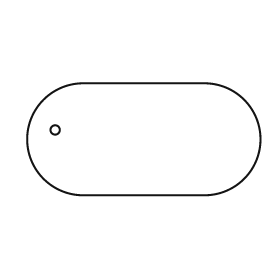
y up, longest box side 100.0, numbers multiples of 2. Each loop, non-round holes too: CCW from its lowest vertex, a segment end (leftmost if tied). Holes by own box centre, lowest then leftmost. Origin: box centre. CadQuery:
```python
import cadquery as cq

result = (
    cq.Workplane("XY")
    .moveTo(-26.0, -24.0)
    .lineTo(26.0, -24.0)
    .threePointArc((50.0, 0.0), (26.0, 24.0))
    .lineTo(-26.0, 24.0)
    .threePointArc((-50.0, 0.0), (-26.0, -24.0))
    .close()
    .moveTo(-38.0, 4.0)
    .circle(2.0)
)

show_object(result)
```